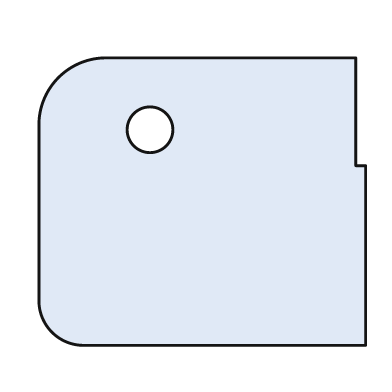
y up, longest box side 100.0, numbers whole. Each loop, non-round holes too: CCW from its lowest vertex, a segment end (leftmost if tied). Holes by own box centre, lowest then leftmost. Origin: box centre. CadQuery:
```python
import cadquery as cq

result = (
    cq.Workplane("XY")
    .moveTo(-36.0, -44.0)
    .lineTo(50.0, -44.0)
    .lineTo(50.0, 11.0)
    .lineTo(47.0, 11.0)
    .lineTo(47.0, 44.0)
    .lineTo(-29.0, 44.0)
    .threePointArc((-44.0, 38.0), (-50.0, 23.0))
    .lineTo(-50.0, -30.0)
    .threePointArc((-46.0, -40.0), (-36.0, -44.0))
    .close()
    .moveTo(-16.0, 22.0)
    .circle(7.0)
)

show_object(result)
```